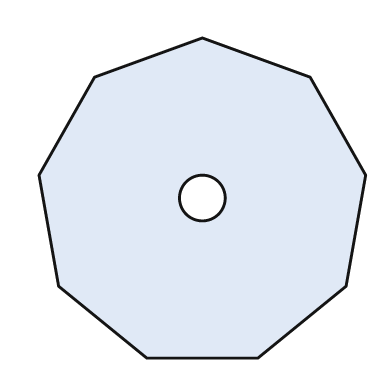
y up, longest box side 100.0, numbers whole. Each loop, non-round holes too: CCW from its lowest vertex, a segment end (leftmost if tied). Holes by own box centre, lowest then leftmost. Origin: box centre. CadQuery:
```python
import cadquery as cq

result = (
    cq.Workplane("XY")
    .moveTo(-17.0, -49.0)
    .lineTo(17.0, -49.0)
    .lineTo(44.0, -27.0)
    .lineTo(50.0, 7.0)
    .lineTo(33.0, 37.0)
    .lineTo(0.0, 49.0)
    .lineTo(-33.0, 37.0)
    .lineTo(-50.0, 7.0)
    .lineTo(-44.0, -27.0)
    .close()
    .moveTo(0.0, 0.0)
    .circle(7.0)
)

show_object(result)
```